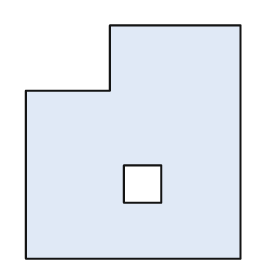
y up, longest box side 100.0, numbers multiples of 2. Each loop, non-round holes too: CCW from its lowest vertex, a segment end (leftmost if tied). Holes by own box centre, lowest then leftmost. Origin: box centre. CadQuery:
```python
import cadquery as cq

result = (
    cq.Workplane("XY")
    .moveTo(-46.0, -50.0)
    .lineTo(46.0, -50.0)
    .lineTo(46.0, 50.0)
    .lineTo(-10.0, 50.0)
    .lineTo(-10.0, 22.0)
    .lineTo(-46.0, 22.0)
    .close()
    .moveTo(-4.0, -26.0)
    .lineTo(12.0, -26.0)
    .lineTo(12.0, -10.0)
    .lineTo(-4.0, -10.0)
    .close()
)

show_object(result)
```